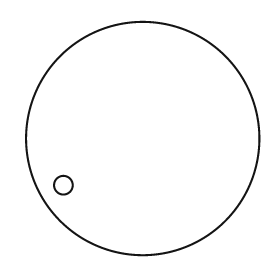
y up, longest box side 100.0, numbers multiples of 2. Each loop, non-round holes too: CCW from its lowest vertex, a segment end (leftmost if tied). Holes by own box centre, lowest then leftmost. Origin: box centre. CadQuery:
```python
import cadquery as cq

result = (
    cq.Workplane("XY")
    .moveTo(0.0, 0.0)
    .circle(50.0)
    .moveTo(-34.0, -20.0)
    .circle(4.0)
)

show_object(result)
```